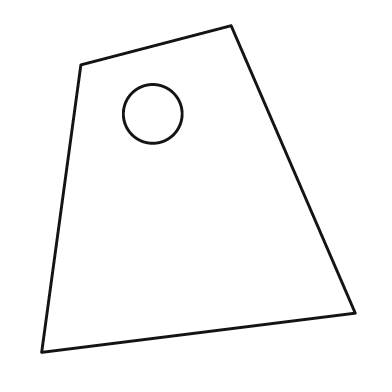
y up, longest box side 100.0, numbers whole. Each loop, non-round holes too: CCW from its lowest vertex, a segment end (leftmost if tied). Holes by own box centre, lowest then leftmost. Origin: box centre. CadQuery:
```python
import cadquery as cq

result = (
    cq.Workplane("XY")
    .moveTo(-48.0, -50.0)
    .lineTo(48.0, -38.0)
    .lineTo(10.0, 50.0)
    .lineTo(-36.0, 38.0)
    .close()
    .moveTo(-14.0, 23.0)
    .circle(9.0)
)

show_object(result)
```